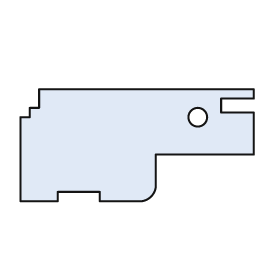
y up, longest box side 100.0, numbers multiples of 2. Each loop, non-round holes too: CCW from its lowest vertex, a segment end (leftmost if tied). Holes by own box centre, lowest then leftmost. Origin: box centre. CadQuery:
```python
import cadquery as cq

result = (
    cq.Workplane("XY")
    .moveTo(-50.0, -24.0)
    .lineTo(-34.0, -24.0)
    .lineTo(-34.0, -20.0)
    .lineTo(-16.0, -20.0)
    .lineTo(-16.0, -24.0)
    .lineTo(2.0, -24.0)
    .threePointArc((6.0, -22.0), (8.0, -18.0))
    .lineTo(8.0, -4.0)
    .lineTo(50.0, -4.0)
    .lineTo(50.0, 14.0)
    .lineTo(36.0, 14.0)
    .lineTo(36.0, 20.0)
    .lineTo(50.0, 20.0)
    .lineTo(50.0, 24.0)
    .lineTo(-42.0, 24.0)
    .lineTo(-42.0, 16.0)
    .lineTo(-46.0, 16.0)
    .lineTo(-46.0, 12.0)
    .lineTo(-50.0, 12.0)
    .close()
    .moveTo(26.0, 12.0)
    .circle(4.0)
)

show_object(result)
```